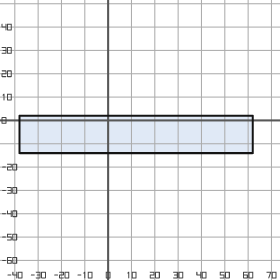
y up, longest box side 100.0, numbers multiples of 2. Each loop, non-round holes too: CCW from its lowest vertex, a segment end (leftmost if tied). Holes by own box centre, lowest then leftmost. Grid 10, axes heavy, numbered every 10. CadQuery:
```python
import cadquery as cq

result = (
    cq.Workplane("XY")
    .moveTo(-38.0, -14.0)
    .lineTo(62.0, -14.0)
    .lineTo(62.0, 2.0)
    .lineTo(-38.0, 2.0)
    .close()
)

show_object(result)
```